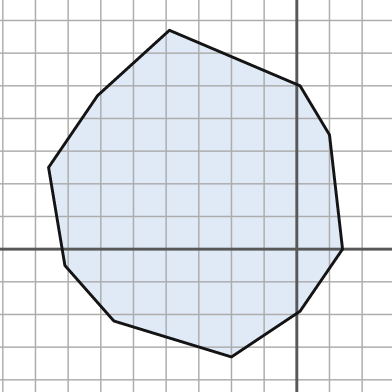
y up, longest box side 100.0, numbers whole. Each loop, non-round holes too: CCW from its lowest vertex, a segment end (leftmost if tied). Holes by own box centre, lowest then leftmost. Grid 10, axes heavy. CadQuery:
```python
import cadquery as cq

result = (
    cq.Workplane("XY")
    .moveTo(-20.0, -33.0)
    .lineTo(1.0, -19.0)
    .lineTo(14.0, 0.0)
    .lineTo(10.0, 35.0)
    .lineTo(1.0, 50.0)
    .lineTo(-39.0, 67.0)
    .lineTo(-61.0, 47.0)
    .lineTo(-76.0, 25.0)
    .lineTo(-71.0, -5.0)
    .lineTo(-56.0, -22.0)
    .close()
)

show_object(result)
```